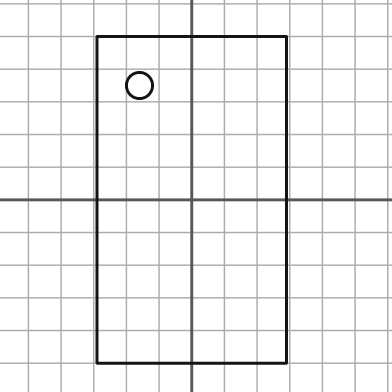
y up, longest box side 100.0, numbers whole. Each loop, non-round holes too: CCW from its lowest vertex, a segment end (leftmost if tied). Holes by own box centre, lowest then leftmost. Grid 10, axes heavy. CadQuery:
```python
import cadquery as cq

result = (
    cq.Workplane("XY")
    .moveTo(-29.0, -50.0)
    .lineTo(29.0, -50.0)
    .lineTo(29.0, 50.0)
    .lineTo(-29.0, 50.0)
    .close()
    .moveTo(-16.0, 35.0)
    .circle(4.0)
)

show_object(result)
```